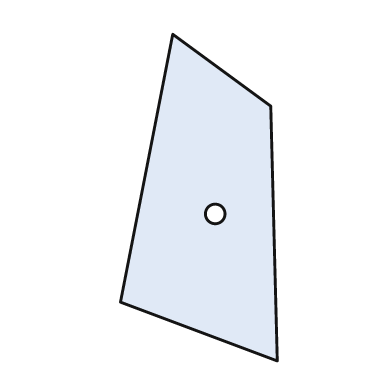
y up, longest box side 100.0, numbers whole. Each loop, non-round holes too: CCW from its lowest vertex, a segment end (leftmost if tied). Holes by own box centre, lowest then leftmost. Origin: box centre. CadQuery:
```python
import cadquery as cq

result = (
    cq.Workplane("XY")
    .moveTo(24.0, -50.0)
    .lineTo(22.0, 28.0)
    .lineTo(-8.0, 50.0)
    .lineTo(-24.0, -32.0)
    .close()
    .moveTo(5.0, -5.0)
    .circle(3.0)
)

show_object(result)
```